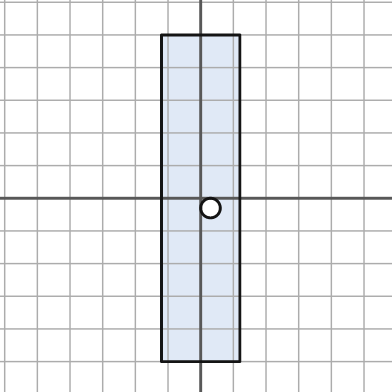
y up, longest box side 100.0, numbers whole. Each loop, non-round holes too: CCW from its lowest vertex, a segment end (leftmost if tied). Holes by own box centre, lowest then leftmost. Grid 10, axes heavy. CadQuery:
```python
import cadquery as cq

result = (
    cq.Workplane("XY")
    .moveTo(-12.0, -50.0)
    .lineTo(12.0, -50.0)
    .lineTo(12.0, 50.0)
    .lineTo(-12.0, 50.0)
    .close()
    .moveTo(3.0, -3.0)
    .circle(3.0)
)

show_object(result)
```